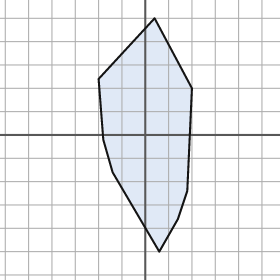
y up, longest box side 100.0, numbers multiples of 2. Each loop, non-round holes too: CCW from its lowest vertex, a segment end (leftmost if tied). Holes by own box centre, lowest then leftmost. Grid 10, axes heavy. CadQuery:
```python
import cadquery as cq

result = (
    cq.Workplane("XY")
    .moveTo(6.0, -50.0)
    .lineTo(14.0, -36.0)
    .lineTo(18.0, -24.0)
    .lineTo(20.0, 20.0)
    .lineTo(4.0, 50.0)
    .lineTo(-20.0, 24.0)
    .lineTo(-18.0, -2.0)
    .lineTo(-14.0, -16.0)
    .close()
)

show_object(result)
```